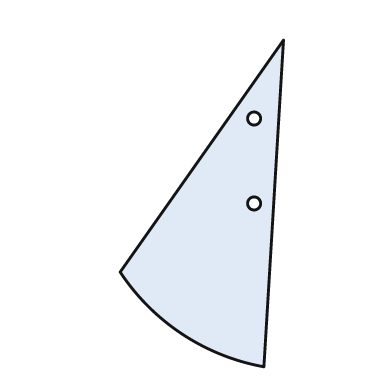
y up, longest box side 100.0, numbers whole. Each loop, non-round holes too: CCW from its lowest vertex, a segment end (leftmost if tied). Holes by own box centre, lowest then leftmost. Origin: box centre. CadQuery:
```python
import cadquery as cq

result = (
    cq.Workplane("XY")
    .moveTo(19.0, -50.0)
    .lineTo(25.0, 50.0)
    .lineTo(-25.0, -21.0)
    .threePointArc((-6.0, -40.0), (19.0, -50.0))
    .close()
    .moveTo(16.0, 0.0)
    .circle(2.0)
    .moveTo(16.0, 26.0)
    .circle(2.0)
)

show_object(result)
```